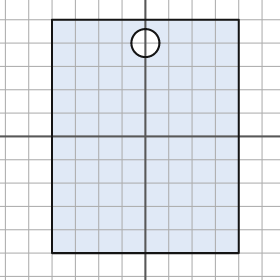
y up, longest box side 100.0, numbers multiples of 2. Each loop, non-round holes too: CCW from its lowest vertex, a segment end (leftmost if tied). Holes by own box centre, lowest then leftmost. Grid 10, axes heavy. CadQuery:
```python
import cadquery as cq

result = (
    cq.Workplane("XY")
    .moveTo(-40.0, -50.0)
    .lineTo(40.0, -50.0)
    .lineTo(40.0, 50.0)
    .lineTo(-40.0, 50.0)
    .close()
    .moveTo(0.0, 40.0)
    .circle(6.0)
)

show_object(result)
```